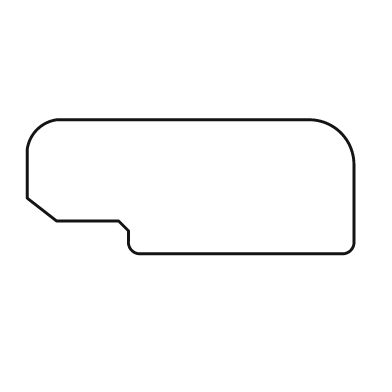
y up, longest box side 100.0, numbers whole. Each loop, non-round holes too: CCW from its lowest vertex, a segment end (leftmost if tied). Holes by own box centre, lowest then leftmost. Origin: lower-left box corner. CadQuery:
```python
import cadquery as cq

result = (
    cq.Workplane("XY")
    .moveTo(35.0, 0.0)
    .lineTo(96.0, 0.0)
    .threePointArc((99.0, 1.0), (100.0, 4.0))
    .lineTo(100.0, 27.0)
    .threePointArc((96.0, 37.0), (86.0, 41.0))
    .lineTo(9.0, 41.0)
    .threePointArc((3.0, 38.0), (0.0, 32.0))
    .lineTo(0.0, 17.0)
    .lineTo(9.0, 10.0)
    .lineTo(28.0, 10.0)
    .lineTo(31.0, 7.0)
    .lineTo(31.0, 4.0)
    .threePointArc((32.0, 1.0), (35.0, 0.0))
    .close()
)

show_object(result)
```